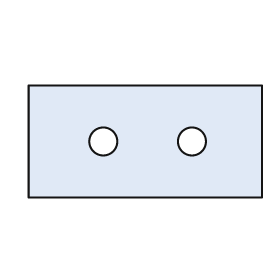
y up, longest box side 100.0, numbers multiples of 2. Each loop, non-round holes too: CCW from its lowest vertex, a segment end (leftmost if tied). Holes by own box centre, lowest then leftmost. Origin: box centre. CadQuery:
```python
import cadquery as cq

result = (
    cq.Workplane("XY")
    .moveTo(-50.0, -24.0)
    .lineTo(50.0, -24.0)
    .lineTo(50.0, 24.0)
    .lineTo(-50.0, 24.0)
    .close()
    .moveTo(-18.0, 0.0)
    .circle(6.0)
    .moveTo(20.0, 0.0)
    .circle(6.0)
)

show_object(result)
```